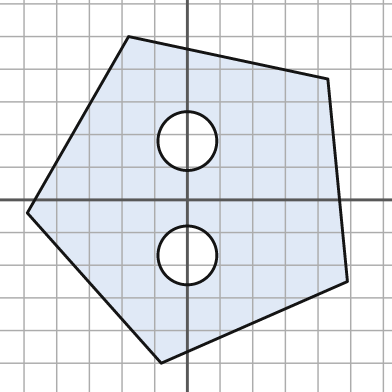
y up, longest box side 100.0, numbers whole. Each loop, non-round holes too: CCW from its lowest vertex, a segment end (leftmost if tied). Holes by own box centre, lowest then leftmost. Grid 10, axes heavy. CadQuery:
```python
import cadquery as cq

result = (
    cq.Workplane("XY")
    .moveTo(-8.0, -50.0)
    .lineTo(49.0, -25.0)
    .lineTo(43.0, 37.0)
    .lineTo(-18.0, 50.0)
    .lineTo(-49.0, -4.0)
    .close()
    .moveTo(0.0, -17.0)
    .circle(9.0)
    .moveTo(0.0, 18.0)
    .circle(9.0)
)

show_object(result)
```